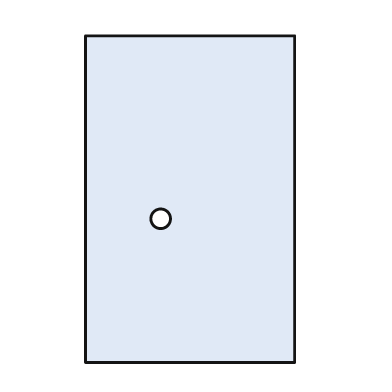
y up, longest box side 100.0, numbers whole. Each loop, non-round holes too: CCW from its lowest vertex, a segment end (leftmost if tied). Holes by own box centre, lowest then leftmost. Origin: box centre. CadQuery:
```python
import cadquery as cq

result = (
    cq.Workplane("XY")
    .moveTo(-32.0, -50.0)
    .lineTo(32.0, -50.0)
    .lineTo(32.0, 50.0)
    .lineTo(-32.0, 50.0)
    .close()
    .moveTo(-9.0, -6.0)
    .circle(3.0)
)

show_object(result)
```